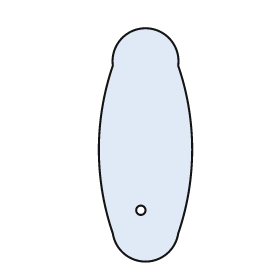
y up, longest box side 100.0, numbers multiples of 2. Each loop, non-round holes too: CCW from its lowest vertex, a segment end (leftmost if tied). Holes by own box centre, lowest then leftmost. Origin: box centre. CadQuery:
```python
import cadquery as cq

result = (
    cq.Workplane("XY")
    .moveTo(-14.0, -38.0)
    .threePointArc((0.0, -50.0), (14.0, -38.0))
    .threePointArc((20.0, -2.0), (14.0, 34.0))
    .threePointArc((0.0, 50.0), (-14.0, 34.0))
    .threePointArc((-20.0, -2.0), (-14.0, -38.0))
    .close()
    .moveTo(-2.0, -28.0)
    .circle(2.0)
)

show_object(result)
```